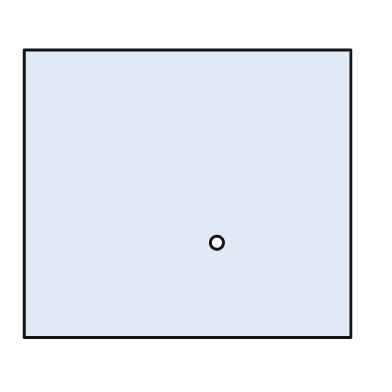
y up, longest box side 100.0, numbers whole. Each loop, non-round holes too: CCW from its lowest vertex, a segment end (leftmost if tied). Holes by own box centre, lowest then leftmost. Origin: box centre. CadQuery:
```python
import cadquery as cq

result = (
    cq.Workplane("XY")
    .moveTo(-50.0, -44.0)
    .lineTo(50.0, -44.0)
    .lineTo(50.0, 44.0)
    .lineTo(-50.0, 44.0)
    .close()
    .moveTo(9.0, -15.0)
    .circle(2.0)
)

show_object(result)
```